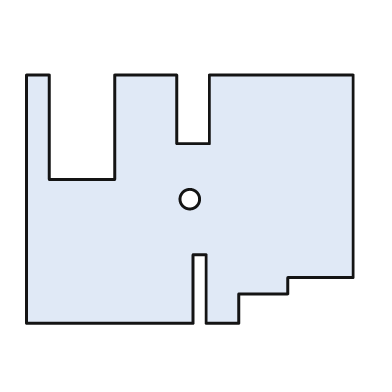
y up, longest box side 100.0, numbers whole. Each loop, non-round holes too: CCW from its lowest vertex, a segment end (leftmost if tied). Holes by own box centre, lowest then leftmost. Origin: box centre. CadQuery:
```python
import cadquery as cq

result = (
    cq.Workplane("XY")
    .moveTo(-50.0, -38.0)
    .lineTo(1.0, -38.0)
    .lineTo(1.0, -17.0)
    .lineTo(5.0, -17.0)
    .lineTo(5.0, -38.0)
    .lineTo(15.0, -38.0)
    .lineTo(15.0, -29.0)
    .lineTo(30.0, -29.0)
    .lineTo(30.0, -24.0)
    .lineTo(50.0, -24.0)
    .lineTo(50.0, 38.0)
    .lineTo(6.0, 38.0)
    .lineTo(6.0, 17.0)
    .lineTo(-4.0, 17.0)
    .lineTo(-4.0, 38.0)
    .lineTo(-23.0, 38.0)
    .lineTo(-23.0, 6.0)
    .lineTo(-43.0, 6.0)
    .lineTo(-43.0, 38.0)
    .lineTo(-50.0, 38.0)
    .close()
    .moveTo(0.0, 0.0)
    .circle(3.0)
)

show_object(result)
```